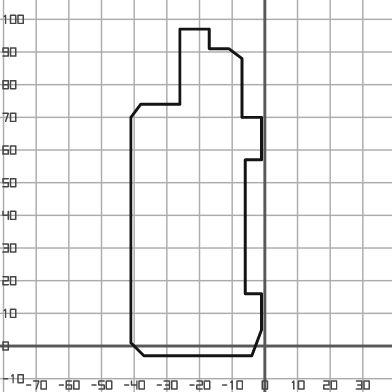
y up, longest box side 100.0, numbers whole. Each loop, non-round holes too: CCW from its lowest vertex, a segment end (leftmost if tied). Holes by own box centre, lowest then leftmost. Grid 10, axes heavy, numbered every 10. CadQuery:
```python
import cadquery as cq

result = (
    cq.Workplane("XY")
    .moveTo(-37.0, -3.0)
    .lineTo(-4.0, -3.0)
    .lineTo(-1.0, 5.0)
    .lineTo(-1.0, 16.0)
    .lineTo(-6.0, 16.0)
    .lineTo(-6.0, 57.0)
    .lineTo(-1.0, 57.0)
    .lineTo(-1.0, 70.0)
    .lineTo(-7.0, 70.0)
    .lineTo(-7.0, 88.0)
    .lineTo(-11.0, 91.0)
    .lineTo(-17.0, 91.0)
    .lineTo(-17.0, 97.0)
    .lineTo(-26.0, 97.0)
    .lineTo(-26.0, 74.0)
    .lineTo(-38.0, 74.0)
    .lineTo(-41.0, 70.0)
    .lineTo(-41.0, 1.0)
    .close()
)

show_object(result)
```